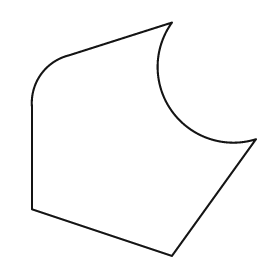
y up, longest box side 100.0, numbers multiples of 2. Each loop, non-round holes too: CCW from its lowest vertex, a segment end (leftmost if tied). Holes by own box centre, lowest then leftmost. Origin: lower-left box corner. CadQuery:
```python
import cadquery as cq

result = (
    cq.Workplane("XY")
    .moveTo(60.0, 0.0)
    .lineTo(96.0, 50.0)
    .threePointArc((60.0, 62.0), (60.0, 100.0))
    .lineTo(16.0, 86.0)
    .threePointArc((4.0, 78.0), (0.0, 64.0))
    .lineTo(0.0, 20.0)
    .close()
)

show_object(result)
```